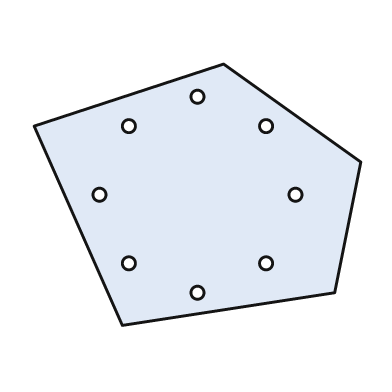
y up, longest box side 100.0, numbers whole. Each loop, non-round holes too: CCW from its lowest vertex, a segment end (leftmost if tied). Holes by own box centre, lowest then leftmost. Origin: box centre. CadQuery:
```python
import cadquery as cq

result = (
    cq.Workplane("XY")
    .moveTo(-23.0, -40.0)
    .lineTo(42.0, -30.0)
    .lineTo(50.0, 10.0)
    .lineTo(8.0, 40.0)
    .lineTo(-50.0, 21.0)
    .close()
    .moveTo(0.0, -30.0)
    .circle(2.0)
    .moveTo(-21.0, -21.0)
    .circle(2.0)
    .moveTo(21.0, -21.0)
    .circle(2.0)
    .moveTo(-30.0, 0.0)
    .circle(2.0)
    .moveTo(30.0, 0.0)
    .circle(2.0)
    .moveTo(-21.0, 21.0)
    .circle(2.0)
    .moveTo(21.0, 21.0)
    .circle(2.0)
    .moveTo(0.0, 30.0)
    .circle(2.0)
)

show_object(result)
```